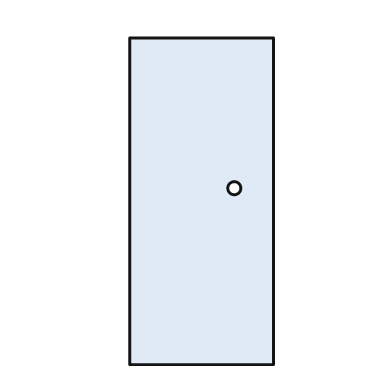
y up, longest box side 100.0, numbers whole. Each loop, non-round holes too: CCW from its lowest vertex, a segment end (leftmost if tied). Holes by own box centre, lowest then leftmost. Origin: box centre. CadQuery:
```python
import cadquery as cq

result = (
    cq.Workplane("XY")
    .moveTo(-22.0, -50.0)
    .lineTo(22.0, -50.0)
    .lineTo(22.0, 50.0)
    .lineTo(-22.0, 50.0)
    .close()
    .moveTo(10.0, 4.0)
    .circle(2.0)
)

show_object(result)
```